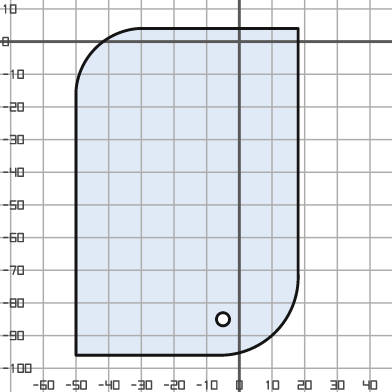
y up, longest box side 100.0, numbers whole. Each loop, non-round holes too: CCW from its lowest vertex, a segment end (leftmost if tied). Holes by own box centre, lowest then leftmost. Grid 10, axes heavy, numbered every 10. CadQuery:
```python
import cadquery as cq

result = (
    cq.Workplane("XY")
    .moveTo(-50.0, -96.0)
    .lineTo(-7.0, -96.0)
    .threePointArc((11.0, -89.0), (18.0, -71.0))
    .lineTo(18.0, 4.0)
    .lineTo(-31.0, 4.0)
    .threePointArc((-44.0, -2.0), (-50.0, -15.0))
    .close()
    .moveTo(-5.0, -85.0)
    .circle(2.0)
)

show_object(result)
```